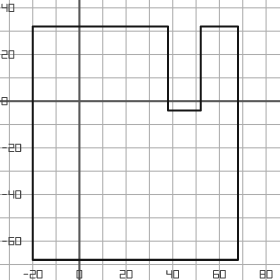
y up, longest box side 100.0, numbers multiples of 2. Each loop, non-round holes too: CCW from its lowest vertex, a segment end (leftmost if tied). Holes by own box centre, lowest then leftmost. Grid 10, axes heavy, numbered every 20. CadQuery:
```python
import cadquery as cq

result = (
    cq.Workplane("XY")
    .moveTo(-20.0, -68.0)
    .lineTo(68.0, -68.0)
    .lineTo(68.0, 32.0)
    .lineTo(52.0, 32.0)
    .lineTo(52.0, -4.0)
    .lineTo(38.0, -4.0)
    .lineTo(38.0, 32.0)
    .lineTo(-20.0, 32.0)
    .close()
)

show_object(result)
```